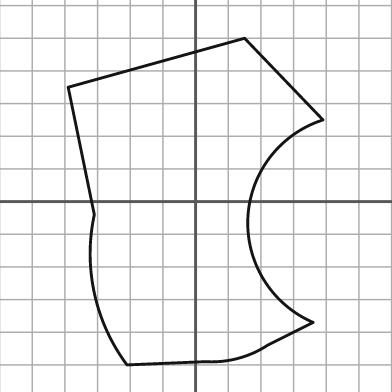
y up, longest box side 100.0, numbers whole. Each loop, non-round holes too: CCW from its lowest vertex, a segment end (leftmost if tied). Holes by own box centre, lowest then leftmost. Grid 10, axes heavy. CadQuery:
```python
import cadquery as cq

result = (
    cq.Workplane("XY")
    .moveTo(-21.0, -50.0)
    .lineTo(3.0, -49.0)
    .threePointArc((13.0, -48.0), (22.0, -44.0))
    .lineTo(36.0, -37.0)
    .threePointArc((16.0, -5.0), (39.0, 25.0))
    .lineTo(15.0, 50.0)
    .lineTo(-39.0, 35.0)
    .lineTo(-31.0, -4.0)
    .threePointArc((-31.0, -28.0), (-21.0, -50.0))
    .close()
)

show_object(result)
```